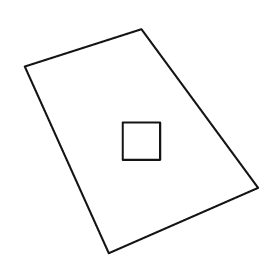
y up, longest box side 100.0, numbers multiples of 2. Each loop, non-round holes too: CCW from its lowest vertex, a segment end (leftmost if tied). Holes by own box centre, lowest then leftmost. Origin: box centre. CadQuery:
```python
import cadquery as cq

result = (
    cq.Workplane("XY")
    .moveTo(-14.0, -48.0)
    .lineTo(50.0, -20.0)
    .lineTo(0.0, 48.0)
    .lineTo(-50.0, 32.0)
    .close()
    .moveTo(-8.0, -8.0)
    .lineTo(8.0, -8.0)
    .lineTo(8.0, 8.0)
    .lineTo(-8.0, 8.0)
    .close()
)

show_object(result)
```